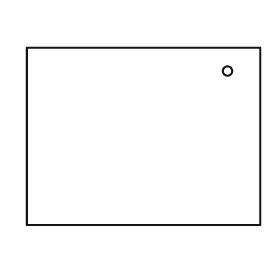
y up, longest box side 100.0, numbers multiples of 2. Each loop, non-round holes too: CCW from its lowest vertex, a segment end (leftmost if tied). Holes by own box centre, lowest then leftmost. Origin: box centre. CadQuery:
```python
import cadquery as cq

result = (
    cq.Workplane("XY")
    .moveTo(-50.0, -38.0)
    .lineTo(50.0, -38.0)
    .lineTo(50.0, 38.0)
    .lineTo(-50.0, 38.0)
    .close()
    .moveTo(36.0, 28.0)
    .circle(2.0)
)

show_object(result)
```